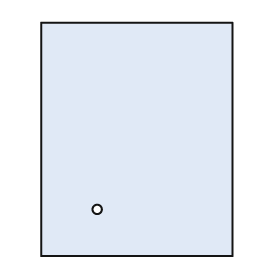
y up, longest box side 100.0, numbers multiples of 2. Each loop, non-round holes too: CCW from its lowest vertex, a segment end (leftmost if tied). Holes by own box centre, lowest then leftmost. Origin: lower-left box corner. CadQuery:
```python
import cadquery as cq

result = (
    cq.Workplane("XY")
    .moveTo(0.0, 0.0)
    .lineTo(82.0, 0.0)
    .lineTo(82.0, 100.0)
    .lineTo(0.0, 100.0)
    .close()
    .moveTo(24.0, 20.0)
    .circle(2.0)
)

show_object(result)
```